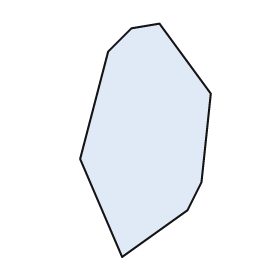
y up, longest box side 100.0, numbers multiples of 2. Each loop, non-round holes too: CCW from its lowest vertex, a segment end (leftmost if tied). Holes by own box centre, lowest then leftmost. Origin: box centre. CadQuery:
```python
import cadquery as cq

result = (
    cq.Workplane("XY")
    .moveTo(-10.0, -50.0)
    .lineTo(18.0, -30.0)
    .lineTo(24.0, -18.0)
    .lineTo(28.0, 20.0)
    .lineTo(6.0, 50.0)
    .lineTo(-6.0, 48.0)
    .lineTo(-16.0, 38.0)
    .lineTo(-28.0, -8.0)
    .close()
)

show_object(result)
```